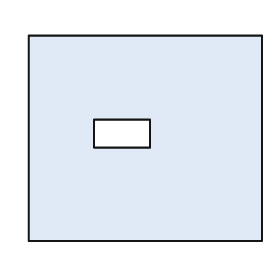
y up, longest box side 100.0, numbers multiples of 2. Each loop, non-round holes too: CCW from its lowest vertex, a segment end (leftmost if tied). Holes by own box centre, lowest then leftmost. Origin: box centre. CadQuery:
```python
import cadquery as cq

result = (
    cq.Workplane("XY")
    .moveTo(-50.0, -44.0)
    .lineTo(50.0, -44.0)
    .lineTo(50.0, 44.0)
    .lineTo(-50.0, 44.0)
    .close()
    .moveTo(-22.0, -4.0)
    .lineTo(2.0, -4.0)
    .lineTo(2.0, 8.0)
    .lineTo(-22.0, 8.0)
    .close()
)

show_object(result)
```